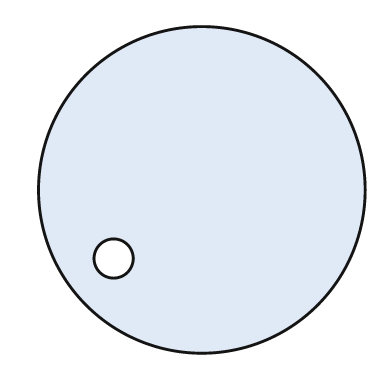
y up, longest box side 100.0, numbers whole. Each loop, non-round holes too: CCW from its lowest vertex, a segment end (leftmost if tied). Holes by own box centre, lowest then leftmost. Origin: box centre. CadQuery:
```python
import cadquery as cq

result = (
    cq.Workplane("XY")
    .moveTo(0.0, 0.0)
    .circle(50.0)
    .moveTo(-27.0, -21.0)
    .circle(6.0)
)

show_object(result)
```